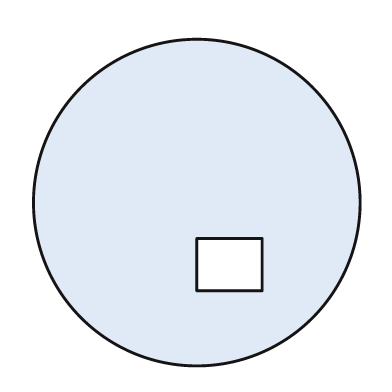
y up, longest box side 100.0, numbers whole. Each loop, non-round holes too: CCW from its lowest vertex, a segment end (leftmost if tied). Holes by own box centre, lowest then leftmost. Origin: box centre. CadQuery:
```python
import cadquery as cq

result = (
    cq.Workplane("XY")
    .moveTo(0.0, 0.0)
    .circle(50.0)
    .moveTo(0.0, -27.0)
    .lineTo(20.0, -27.0)
    .lineTo(20.0, -11.0)
    .lineTo(0.0, -11.0)
    .close()
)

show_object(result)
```